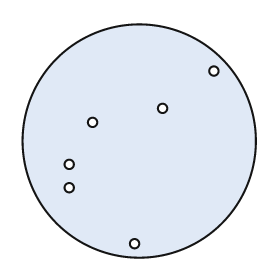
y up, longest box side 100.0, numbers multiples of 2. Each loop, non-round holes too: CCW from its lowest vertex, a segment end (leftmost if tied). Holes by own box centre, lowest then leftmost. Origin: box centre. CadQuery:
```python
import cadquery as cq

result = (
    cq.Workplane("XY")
    .moveTo(0.0, 0.0)
    .circle(50.0)
    .moveTo(-2.0, -44.0)
    .circle(2.0)
    .moveTo(-30.0, -20.0)
    .circle(2.0)
    .moveTo(-30.0, -10.0)
    .circle(2.0)
    .moveTo(-20.0, 8.0)
    .circle(2.0)
    .moveTo(10.0, 14.0)
    .circle(2.0)
    .moveTo(32.0, 30.0)
    .circle(2.0)
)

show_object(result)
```